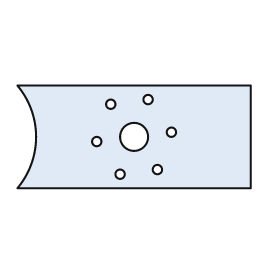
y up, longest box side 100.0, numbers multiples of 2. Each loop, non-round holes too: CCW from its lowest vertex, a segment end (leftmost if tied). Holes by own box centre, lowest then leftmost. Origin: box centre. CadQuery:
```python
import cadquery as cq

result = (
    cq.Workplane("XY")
    .moveTo(-50.0, -22.0)
    .lineTo(50.0, -22.0)
    .lineTo(50.0, 22.0)
    .lineTo(-50.0, 22.0)
    .threePointArc((-42.0, 0.0), (-50.0, -22.0))
    .close()
    .moveTo(-6.0, -16.0)
    .circle(2.0)
    .moveTo(10.0, -14.0)
    .circle(2.0)
    .moveTo(-16.0, -2.0)
    .circle(2.0)
    .moveTo(0.0, 0.0)
    .circle(6.0)
    .moveTo(16.0, 2.0)
    .circle(2.0)
    .moveTo(-10.0, 14.0)
    .circle(2.0)
    .moveTo(6.0, 16.0)
    .circle(2.0)
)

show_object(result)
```